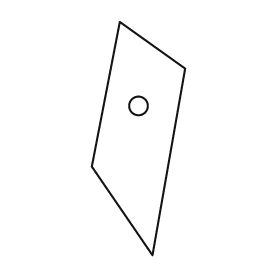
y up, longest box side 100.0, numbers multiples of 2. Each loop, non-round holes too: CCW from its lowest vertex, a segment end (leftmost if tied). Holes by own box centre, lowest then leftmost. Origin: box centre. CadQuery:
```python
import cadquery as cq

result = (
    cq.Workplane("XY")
    .moveTo(6.0, -50.0)
    .lineTo(20.0, 30.0)
    .lineTo(-8.0, 50.0)
    .lineTo(-20.0, -12.0)
    .close()
    .moveTo(0.0, 14.0)
    .circle(4.0)
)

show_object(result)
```